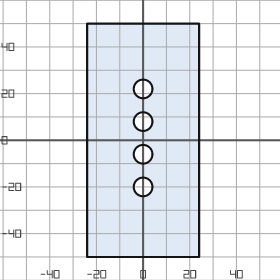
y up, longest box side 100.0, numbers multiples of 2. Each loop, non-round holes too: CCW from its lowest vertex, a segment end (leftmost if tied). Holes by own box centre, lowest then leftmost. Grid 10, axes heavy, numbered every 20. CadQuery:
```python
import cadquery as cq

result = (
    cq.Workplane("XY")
    .moveTo(-24.0, -50.0)
    .lineTo(24.0, -50.0)
    .lineTo(24.0, 50.0)
    .lineTo(-24.0, 50.0)
    .close()
    .moveTo(0.0, -20.0)
    .circle(4.0)
    .moveTo(0.0, -6.0)
    .circle(4.0)
    .moveTo(0.0, 8.0)
    .circle(4.0)
    .moveTo(0.0, 22.0)
    .circle(4.0)
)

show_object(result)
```